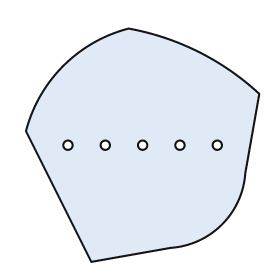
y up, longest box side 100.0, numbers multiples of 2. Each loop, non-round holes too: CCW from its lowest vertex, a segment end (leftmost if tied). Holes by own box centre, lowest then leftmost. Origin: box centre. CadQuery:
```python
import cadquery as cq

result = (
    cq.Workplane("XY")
    .moveTo(-22.0, -50.0)
    .lineTo(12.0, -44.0)
    .threePointArc((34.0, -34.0), (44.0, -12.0))
    .lineTo(50.0, 22.0)
    .threePointArc((24.0, 40.0), (-6.0, 50.0))
    .threePointArc((-34.0, 34.0), (-50.0, 6.0))
    .close()
    .moveTo(-32.0, 0.0)
    .circle(2.0)
    .moveTo(-16.0, 0.0)
    .circle(2.0)
    .moveTo(0.0, 0.0)
    .circle(2.0)
    .moveTo(16.0, 0.0)
    .circle(2.0)
    .moveTo(32.0, 0.0)
    .circle(2.0)
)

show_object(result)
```